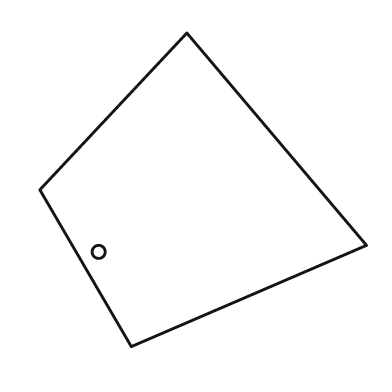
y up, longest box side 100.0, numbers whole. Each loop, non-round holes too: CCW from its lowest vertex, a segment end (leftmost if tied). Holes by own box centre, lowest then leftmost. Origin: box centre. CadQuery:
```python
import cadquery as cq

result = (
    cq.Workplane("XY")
    .moveTo(-22.0, -48.0)
    .lineTo(50.0, -17.0)
    .lineTo(-5.0, 48.0)
    .lineTo(-50.0, 0.0)
    .close()
    .moveTo(-32.0, -19.0)
    .circle(2.0)
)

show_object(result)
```